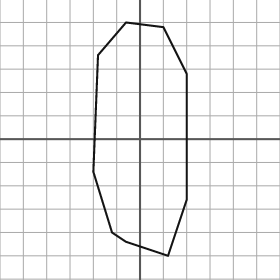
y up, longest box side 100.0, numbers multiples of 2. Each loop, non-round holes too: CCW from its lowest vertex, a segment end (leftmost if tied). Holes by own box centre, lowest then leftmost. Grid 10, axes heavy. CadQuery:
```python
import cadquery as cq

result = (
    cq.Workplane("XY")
    .moveTo(12.0, -50.0)
    .lineTo(20.0, -26.0)
    .lineTo(20.0, 28.0)
    .lineTo(10.0, 48.0)
    .lineTo(-6.0, 50.0)
    .lineTo(-18.0, 36.0)
    .lineTo(-20.0, -14.0)
    .lineTo(-12.0, -40.0)
    .lineTo(-6.0, -44.0)
    .close()
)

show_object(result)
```